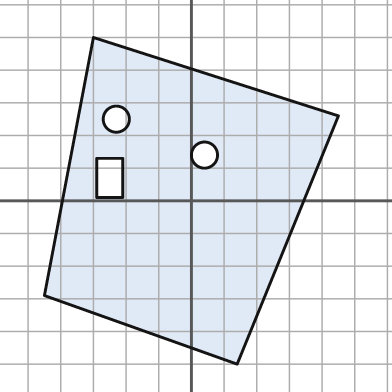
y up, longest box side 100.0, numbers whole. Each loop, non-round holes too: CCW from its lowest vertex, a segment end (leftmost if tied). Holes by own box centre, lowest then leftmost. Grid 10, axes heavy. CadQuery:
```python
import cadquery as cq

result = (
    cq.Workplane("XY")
    .moveTo(14.0, -50.0)
    .lineTo(45.0, 26.0)
    .lineTo(-30.0, 50.0)
    .lineTo(-45.0, -29.0)
    .close()
    .moveTo(-29.0, 1.0)
    .lineTo(-21.0, 1.0)
    .lineTo(-21.0, 13.0)
    .lineTo(-29.0, 13.0)
    .close()
    .moveTo(4.0, 14.0)
    .circle(4.0)
    .moveTo(-23.0, 25.0)
    .circle(4.0)
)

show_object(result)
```